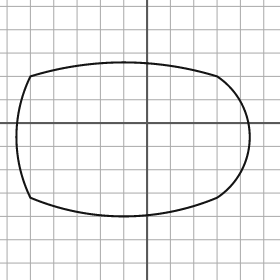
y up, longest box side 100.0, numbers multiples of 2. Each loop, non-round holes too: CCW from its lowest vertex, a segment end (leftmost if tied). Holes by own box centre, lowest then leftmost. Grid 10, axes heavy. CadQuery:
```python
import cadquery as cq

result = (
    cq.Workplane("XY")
    .moveTo(-50.0, -32.0)
    .threePointArc((-10.0, -40.0), (30.0, -32.0))
    .threePointArc((44.0, -6.0), (30.0, 20.0))
    .threePointArc((-10.0, 26.0), (-50.0, 20.0))
    .threePointArc((-56.0, -6.0), (-50.0, -32.0))
    .close()
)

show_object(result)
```